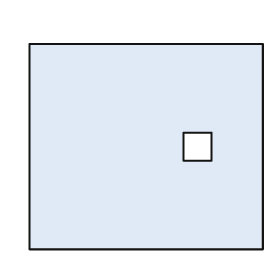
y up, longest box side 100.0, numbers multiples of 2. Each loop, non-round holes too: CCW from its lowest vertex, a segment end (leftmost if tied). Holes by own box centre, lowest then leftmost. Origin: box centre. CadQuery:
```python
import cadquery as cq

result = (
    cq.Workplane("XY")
    .moveTo(-50.0, -44.0)
    .lineTo(50.0, -44.0)
    .lineTo(50.0, 44.0)
    .lineTo(-50.0, 44.0)
    .close()
    .moveTo(16.0, -6.0)
    .lineTo(28.0, -6.0)
    .lineTo(28.0, 6.0)
    .lineTo(16.0, 6.0)
    .close()
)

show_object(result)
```